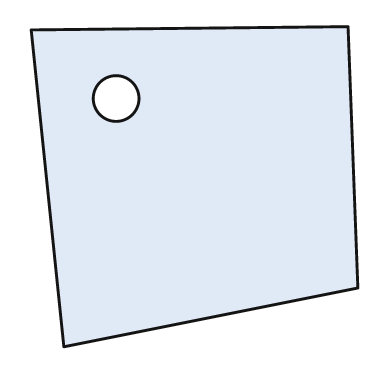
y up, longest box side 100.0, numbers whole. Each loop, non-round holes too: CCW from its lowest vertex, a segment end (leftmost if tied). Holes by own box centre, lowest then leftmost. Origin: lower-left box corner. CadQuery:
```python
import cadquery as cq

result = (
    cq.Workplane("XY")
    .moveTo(10.0, 0.0)
    .lineTo(100.0, 18.0)
    .lineTo(97.0, 98.0)
    .lineTo(0.0, 97.0)
    .close()
    .moveTo(26.0, 76.0)
    .circle(7.0)
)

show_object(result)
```